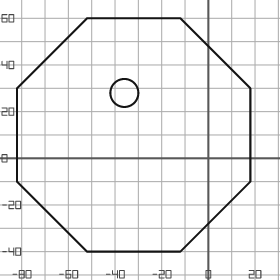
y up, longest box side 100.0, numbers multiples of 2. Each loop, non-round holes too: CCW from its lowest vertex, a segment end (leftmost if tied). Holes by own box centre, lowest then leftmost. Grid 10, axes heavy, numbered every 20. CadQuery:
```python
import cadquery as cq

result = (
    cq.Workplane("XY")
    .moveTo(-52.0, -40.0)
    .lineTo(-12.0, -40.0)
    .lineTo(18.0, -10.0)
    .lineTo(18.0, 30.0)
    .lineTo(-12.0, 60.0)
    .lineTo(-52.0, 60.0)
    .lineTo(-82.0, 30.0)
    .lineTo(-82.0, -10.0)
    .close()
    .moveTo(-36.0, 28.0)
    .circle(6.0)
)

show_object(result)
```